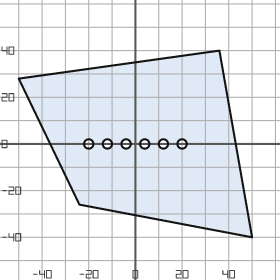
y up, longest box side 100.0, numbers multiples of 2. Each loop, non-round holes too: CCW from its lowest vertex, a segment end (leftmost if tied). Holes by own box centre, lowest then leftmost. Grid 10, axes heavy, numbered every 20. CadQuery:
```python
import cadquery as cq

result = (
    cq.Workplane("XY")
    .moveTo(50.0, -40.0)
    .lineTo(36.0, 40.0)
    .lineTo(-50.0, 28.0)
    .lineTo(-24.0, -26.0)
    .close()
    .moveTo(-20.0, 0.0)
    .circle(2.0)
    .moveTo(-12.0, 0.0)
    .circle(2.0)
    .moveTo(-4.0, 0.0)
    .circle(2.0)
    .moveTo(4.0, 0.0)
    .circle(2.0)
    .moveTo(12.0, 0.0)
    .circle(2.0)
    .moveTo(20.0, 0.0)
    .circle(2.0)
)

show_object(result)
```